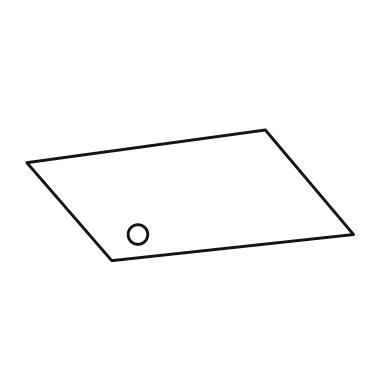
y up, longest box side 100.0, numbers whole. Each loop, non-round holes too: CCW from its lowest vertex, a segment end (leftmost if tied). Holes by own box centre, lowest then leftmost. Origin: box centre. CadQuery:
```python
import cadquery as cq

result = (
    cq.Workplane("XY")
    .moveTo(-24.0, -20.0)
    .lineTo(50.0, -12.0)
    .lineTo(23.0, 20.0)
    .lineTo(-50.0, 10.0)
    .close()
    .moveTo(-16.0, -12.0)
    .circle(3.0)
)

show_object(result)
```